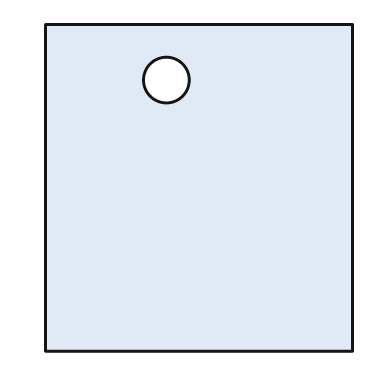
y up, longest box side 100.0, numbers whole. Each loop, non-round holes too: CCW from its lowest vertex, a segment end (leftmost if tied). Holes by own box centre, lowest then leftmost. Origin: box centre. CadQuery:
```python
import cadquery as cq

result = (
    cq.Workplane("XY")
    .moveTo(-47.0, -50.0)
    .lineTo(47.0, -50.0)
    .lineTo(47.0, 50.0)
    .lineTo(-47.0, 50.0)
    .close()
    .moveTo(-10.0, 33.0)
    .circle(7.0)
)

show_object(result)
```